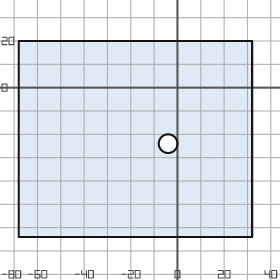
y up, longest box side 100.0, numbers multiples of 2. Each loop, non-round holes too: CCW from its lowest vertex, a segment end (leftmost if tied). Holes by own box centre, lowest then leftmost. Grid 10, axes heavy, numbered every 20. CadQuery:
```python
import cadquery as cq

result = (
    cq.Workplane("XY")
    .moveTo(-68.0, -64.0)
    .lineTo(32.0, -64.0)
    .lineTo(32.0, 20.0)
    .lineTo(-68.0, 20.0)
    .close()
    .moveTo(-4.0, -24.0)
    .circle(4.0)
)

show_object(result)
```